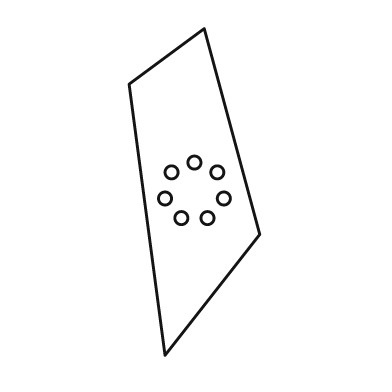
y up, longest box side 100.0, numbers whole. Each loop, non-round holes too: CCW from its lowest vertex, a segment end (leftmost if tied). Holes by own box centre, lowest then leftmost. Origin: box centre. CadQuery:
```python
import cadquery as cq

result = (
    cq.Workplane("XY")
    .moveTo(-9.0, -50.0)
    .lineTo(20.0, -13.0)
    .lineTo(3.0, 50.0)
    .lineTo(-20.0, 33.0)
    .close()
    .moveTo(-4.0, -8.0)
    .circle(2.0)
    .moveTo(4.0, -8.0)
    .circle(2.0)
    .moveTo(-9.0, -2.0)
    .circle(2.0)
    .moveTo(9.0, -2.0)
    .circle(2.0)
    .moveTo(-7.0, 6.0)
    .circle(2.0)
    .moveTo(7.0, 6.0)
    .circle(2.0)
    .moveTo(0.0, 9.0)
    .circle(2.0)
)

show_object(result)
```